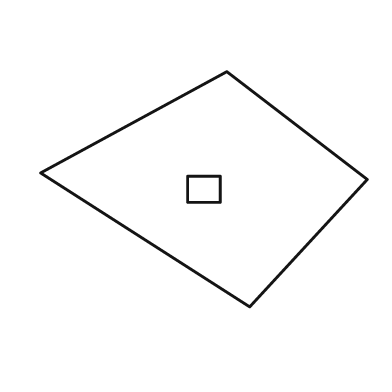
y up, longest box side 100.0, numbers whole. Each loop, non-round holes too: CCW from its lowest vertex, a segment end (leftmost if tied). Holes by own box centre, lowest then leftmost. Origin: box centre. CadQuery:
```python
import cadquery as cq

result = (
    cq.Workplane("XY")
    .moveTo(14.0, -36.0)
    .lineTo(50.0, 3.0)
    .lineTo(7.0, 36.0)
    .lineTo(-50.0, 5.0)
    .close()
    .moveTo(-5.0, -4.0)
    .lineTo(5.0, -4.0)
    .lineTo(5.0, 4.0)
    .lineTo(-5.0, 4.0)
    .close()
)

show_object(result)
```